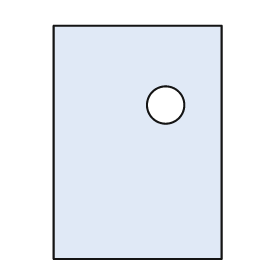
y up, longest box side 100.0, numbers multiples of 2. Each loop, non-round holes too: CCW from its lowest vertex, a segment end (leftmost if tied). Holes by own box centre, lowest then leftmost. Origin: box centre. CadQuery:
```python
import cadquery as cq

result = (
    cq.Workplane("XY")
    .moveTo(-36.0, -50.0)
    .lineTo(36.0, -50.0)
    .lineTo(36.0, 50.0)
    .lineTo(-36.0, 50.0)
    .close()
    .moveTo(12.0, 16.0)
    .circle(8.0)
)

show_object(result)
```